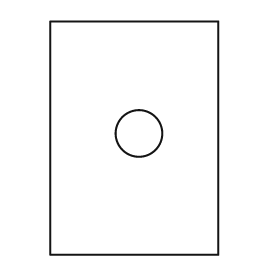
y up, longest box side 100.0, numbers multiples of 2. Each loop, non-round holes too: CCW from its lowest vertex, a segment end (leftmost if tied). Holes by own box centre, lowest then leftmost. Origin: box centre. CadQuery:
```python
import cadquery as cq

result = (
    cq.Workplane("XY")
    .moveTo(-36.0, -50.0)
    .lineTo(36.0, -50.0)
    .lineTo(36.0, 50.0)
    .lineTo(-36.0, 50.0)
    .close()
    .moveTo(2.0, 2.0)
    .circle(10.0)
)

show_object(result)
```